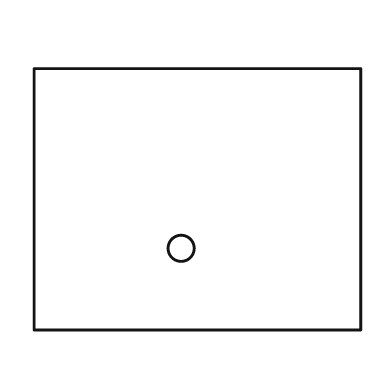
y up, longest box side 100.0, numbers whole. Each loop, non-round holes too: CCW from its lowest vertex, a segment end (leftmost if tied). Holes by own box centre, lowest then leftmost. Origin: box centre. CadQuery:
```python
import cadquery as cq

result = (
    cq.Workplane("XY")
    .moveTo(-50.0, -40.0)
    .lineTo(50.0, -40.0)
    .lineTo(50.0, 40.0)
    .lineTo(-50.0, 40.0)
    .close()
    .moveTo(-5.0, -15.0)
    .circle(4.0)
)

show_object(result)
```